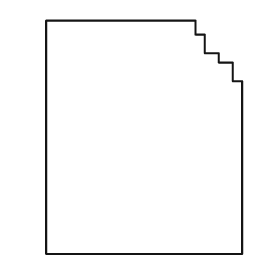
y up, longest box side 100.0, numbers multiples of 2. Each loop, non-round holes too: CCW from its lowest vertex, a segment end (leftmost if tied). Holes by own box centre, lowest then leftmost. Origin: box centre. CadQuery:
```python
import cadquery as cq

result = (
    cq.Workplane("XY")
    .moveTo(-42.0, -50.0)
    .lineTo(42.0, -50.0)
    .lineTo(42.0, 24.0)
    .lineTo(38.0, 24.0)
    .lineTo(38.0, 32.0)
    .lineTo(32.0, 32.0)
    .lineTo(32.0, 36.0)
    .lineTo(26.0, 36.0)
    .lineTo(26.0, 44.0)
    .lineTo(22.0, 44.0)
    .lineTo(22.0, 50.0)
    .lineTo(-42.0, 50.0)
    .close()
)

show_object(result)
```